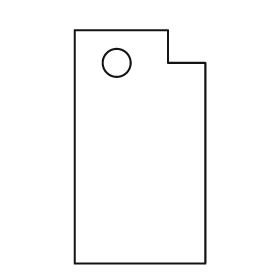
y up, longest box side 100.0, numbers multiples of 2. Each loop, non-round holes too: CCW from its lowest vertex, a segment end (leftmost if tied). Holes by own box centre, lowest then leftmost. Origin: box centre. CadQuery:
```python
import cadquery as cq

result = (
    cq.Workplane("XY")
    .moveTo(-28.0, -50.0)
    .lineTo(28.0, -50.0)
    .lineTo(28.0, 36.0)
    .lineTo(12.0, 36.0)
    .lineTo(12.0, 50.0)
    .lineTo(-28.0, 50.0)
    .close()
    .moveTo(-10.0, 36.0)
    .circle(6.0)
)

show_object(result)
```